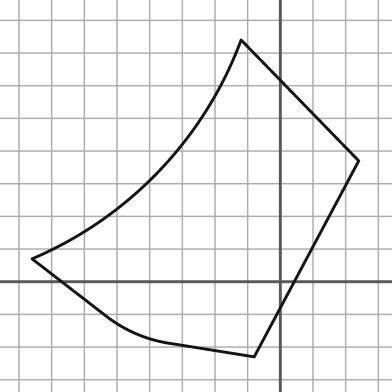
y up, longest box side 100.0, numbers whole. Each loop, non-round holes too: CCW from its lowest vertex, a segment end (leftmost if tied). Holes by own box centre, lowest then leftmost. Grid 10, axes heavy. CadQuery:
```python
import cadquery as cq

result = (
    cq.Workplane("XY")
    .moveTo(-8.0, -23.0)
    .lineTo(24.0, 37.0)
    .lineTo(-12.0, 74.0)
    .threePointArc((-37.0, 34.0), (-76.0, 7.0))
    .lineTo(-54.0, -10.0)
    .threePointArc((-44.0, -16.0), (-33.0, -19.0))
    .close()
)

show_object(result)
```